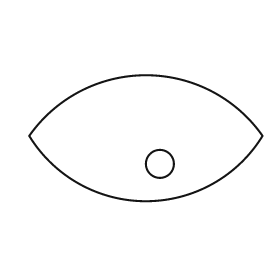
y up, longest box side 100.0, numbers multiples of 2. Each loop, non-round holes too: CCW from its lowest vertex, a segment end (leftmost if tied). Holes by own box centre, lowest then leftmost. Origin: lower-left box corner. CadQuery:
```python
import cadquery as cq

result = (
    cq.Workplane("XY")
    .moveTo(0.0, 28.0)
    .threePointArc((50.0, 0.0), (100.0, 28.0))
    .threePointArc((50.0, 54.0), (0.0, 28.0))
    .close()
    .moveTo(56.0, 16.0)
    .circle(6.0)
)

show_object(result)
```